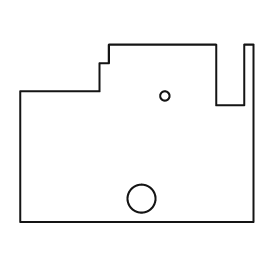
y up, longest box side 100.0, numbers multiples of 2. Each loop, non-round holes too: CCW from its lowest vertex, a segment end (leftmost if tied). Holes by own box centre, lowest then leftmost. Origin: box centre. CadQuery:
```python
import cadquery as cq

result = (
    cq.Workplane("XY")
    .moveTo(-50.0, -38.0)
    .lineTo(50.0, -38.0)
    .lineTo(50.0, 38.0)
    .lineTo(46.0, 38.0)
    .lineTo(46.0, 12.0)
    .lineTo(34.0, 12.0)
    .lineTo(34.0, 38.0)
    .lineTo(-12.0, 38.0)
    .lineTo(-12.0, 30.0)
    .lineTo(-16.0, 30.0)
    .lineTo(-16.0, 18.0)
    .lineTo(-50.0, 18.0)
    .close()
    .moveTo(2.0, -28.0)
    .circle(6.0)
    .moveTo(12.0, 16.0)
    .circle(2.0)
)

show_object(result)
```